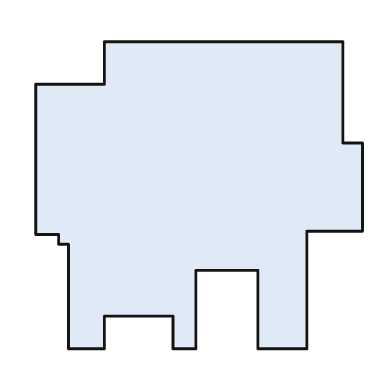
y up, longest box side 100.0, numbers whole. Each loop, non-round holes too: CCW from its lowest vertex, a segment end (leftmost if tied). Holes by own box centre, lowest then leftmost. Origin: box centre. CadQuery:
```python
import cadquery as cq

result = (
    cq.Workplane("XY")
    .moveTo(-40.0, -47.0)
    .lineTo(-29.0, -47.0)
    .lineTo(-29.0, -37.0)
    .lineTo(-8.0, -37.0)
    .lineTo(-8.0, -47.0)
    .lineTo(-1.0, -47.0)
    .lineTo(-1.0, -23.0)
    .lineTo(18.0, -23.0)
    .lineTo(18.0, -47.0)
    .lineTo(33.0, -47.0)
    .lineTo(33.0, -11.0)
    .lineTo(50.0, -11.0)
    .lineTo(50.0, 16.0)
    .lineTo(44.0, 16.0)
    .lineTo(44.0, 47.0)
    .lineTo(-29.0, 47.0)
    .lineTo(-29.0, 34.0)
    .lineTo(-50.0, 34.0)
    .lineTo(-50.0, -12.0)
    .lineTo(-43.0, -12.0)
    .lineTo(-43.0, -15.0)
    .lineTo(-40.0, -15.0)
    .close()
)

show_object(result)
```